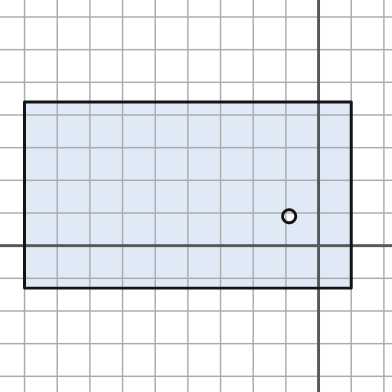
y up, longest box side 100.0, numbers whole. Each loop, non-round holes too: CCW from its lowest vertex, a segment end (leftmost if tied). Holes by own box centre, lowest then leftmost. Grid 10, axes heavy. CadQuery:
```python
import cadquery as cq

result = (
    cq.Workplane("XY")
    .moveTo(-90.0, -13.0)
    .lineTo(10.0, -13.0)
    .lineTo(10.0, 44.0)
    .lineTo(-90.0, 44.0)
    .close()
    .moveTo(-9.0, 9.0)
    .circle(2.0)
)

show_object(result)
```